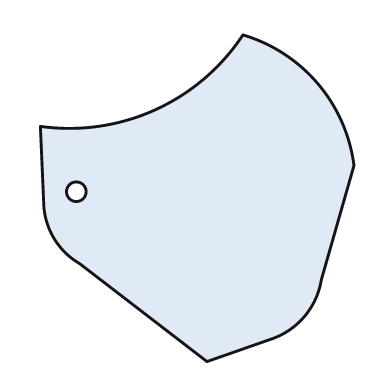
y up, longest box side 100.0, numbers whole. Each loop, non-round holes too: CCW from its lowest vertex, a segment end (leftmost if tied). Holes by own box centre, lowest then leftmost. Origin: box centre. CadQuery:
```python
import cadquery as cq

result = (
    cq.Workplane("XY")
    .moveTo(3.0, -50.0)
    .lineTo(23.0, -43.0)
    .threePointArc((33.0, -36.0), (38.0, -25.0))
    .lineTo(48.0, 10.0)
    .threePointArc((37.0, 35.0), (14.0, 50.0))
    .threePointArc((-13.0, 27.0), (-48.0, 22.0))
    .lineTo(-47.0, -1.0)
    .threePointArc((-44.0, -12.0), (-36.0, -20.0))
    .close()
    .moveTo(-37.0, 2.0)
    .circle(3.0)
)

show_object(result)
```